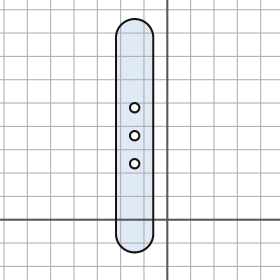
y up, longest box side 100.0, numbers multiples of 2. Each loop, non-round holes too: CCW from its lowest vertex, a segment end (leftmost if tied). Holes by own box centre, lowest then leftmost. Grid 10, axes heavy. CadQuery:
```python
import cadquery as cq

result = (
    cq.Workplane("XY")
    .moveTo(-22.0, -6.0)
    .threePointArc((-14.0, -14.0), (-6.0, -6.0))
    .lineTo(-6.0, 78.0)
    .threePointArc((-14.0, 86.0), (-22.0, 78.0))
    .close()
    .moveTo(-14.0, 24.0)
    .circle(2.0)
    .moveTo(-14.0, 36.0)
    .circle(2.0)
    .moveTo(-14.0, 48.0)
    .circle(2.0)
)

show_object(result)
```